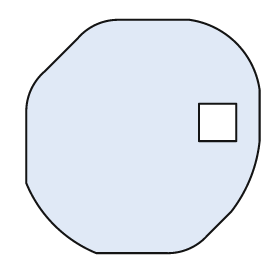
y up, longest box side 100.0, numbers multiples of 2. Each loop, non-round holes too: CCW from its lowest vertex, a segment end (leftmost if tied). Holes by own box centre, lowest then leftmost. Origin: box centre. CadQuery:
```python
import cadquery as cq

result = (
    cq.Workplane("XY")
    .moveTo(-20.0, -50.0)
    .lineTo(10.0, -50.0)
    .threePointArc((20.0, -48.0), (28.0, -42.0))
    .lineTo(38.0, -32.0)
    .threePointArc((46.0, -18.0), (50.0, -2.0))
    .lineTo(50.0, 20.0)
    .threePointArc((40.0, 40.0), (20.0, 50.0))
    .lineTo(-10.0, 50.0)
    .threePointArc((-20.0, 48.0), (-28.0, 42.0))
    .lineTo(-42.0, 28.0)
    .threePointArc((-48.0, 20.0), (-50.0, 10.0))
    .lineTo(-50.0, -20.0)
    .threePointArc((-38.0, -38.0), (-20.0, -50.0))
    .close()
    .moveTo(24.0, -2.0)
    .lineTo(40.0, -2.0)
    .lineTo(40.0, 14.0)
    .lineTo(24.0, 14.0)
    .close()
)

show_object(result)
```